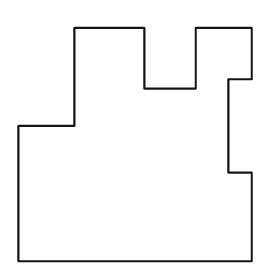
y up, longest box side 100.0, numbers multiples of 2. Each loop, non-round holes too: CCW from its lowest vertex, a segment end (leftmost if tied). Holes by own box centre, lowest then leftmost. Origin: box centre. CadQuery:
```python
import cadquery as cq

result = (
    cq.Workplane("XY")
    .moveTo(-50.0, -50.0)
    .lineTo(50.0, -50.0)
    .lineTo(50.0, -12.0)
    .lineTo(40.0, -12.0)
    .lineTo(40.0, 28.0)
    .lineTo(50.0, 28.0)
    .lineTo(50.0, 50.0)
    .lineTo(26.0, 50.0)
    .lineTo(26.0, 24.0)
    .lineTo(4.0, 24.0)
    .lineTo(4.0, 50.0)
    .lineTo(-26.0, 50.0)
    .lineTo(-26.0, 8.0)
    .lineTo(-50.0, 8.0)
    .close()
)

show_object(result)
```